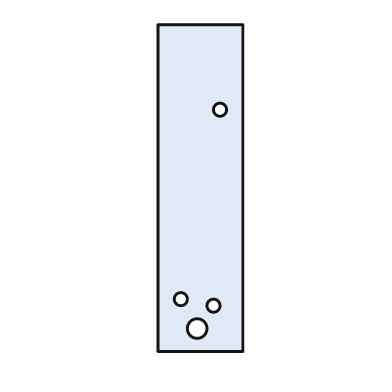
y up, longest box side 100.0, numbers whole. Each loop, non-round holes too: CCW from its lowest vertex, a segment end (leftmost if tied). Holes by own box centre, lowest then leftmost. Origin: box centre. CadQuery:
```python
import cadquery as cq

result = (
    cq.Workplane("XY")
    .moveTo(-13.0, -50.0)
    .lineTo(13.0, -50.0)
    .lineTo(13.0, 50.0)
    .lineTo(-13.0, 50.0)
    .close()
    .moveTo(-1.0, -43.0)
    .circle(3.0)
    .moveTo(4.0, -36.0)
    .circle(2.0)
    .moveTo(-6.0, -34.0)
    .circle(2.0)
    .moveTo(6.0, 24.0)
    .circle(2.0)
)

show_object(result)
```